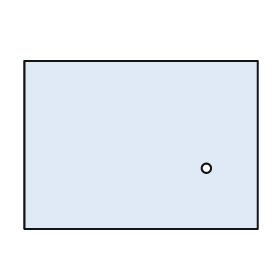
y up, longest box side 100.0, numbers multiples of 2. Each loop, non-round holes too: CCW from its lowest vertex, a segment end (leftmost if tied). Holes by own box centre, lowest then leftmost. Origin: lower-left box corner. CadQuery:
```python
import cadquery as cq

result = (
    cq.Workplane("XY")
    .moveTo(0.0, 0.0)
    .lineTo(100.0, 0.0)
    .lineTo(100.0, 72.0)
    .lineTo(0.0, 72.0)
    .close()
    .moveTo(78.0, 26.0)
    .circle(2.0)
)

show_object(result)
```